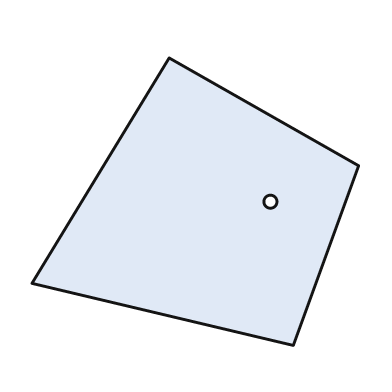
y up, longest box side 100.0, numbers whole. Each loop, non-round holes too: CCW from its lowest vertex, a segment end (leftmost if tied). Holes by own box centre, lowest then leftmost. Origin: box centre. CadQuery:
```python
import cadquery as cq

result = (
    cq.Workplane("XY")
    .moveTo(30.0, -44.0)
    .lineTo(50.0, 11.0)
    .lineTo(-8.0, 44.0)
    .lineTo(-50.0, -25.0)
    .close()
    .moveTo(23.0, 0.0)
    .circle(2.0)
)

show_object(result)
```